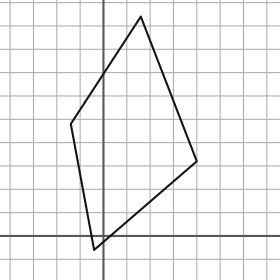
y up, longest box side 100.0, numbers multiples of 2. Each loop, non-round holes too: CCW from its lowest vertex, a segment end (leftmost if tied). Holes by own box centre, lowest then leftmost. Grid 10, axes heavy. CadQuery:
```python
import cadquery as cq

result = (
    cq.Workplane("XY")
    .moveTo(-4.0, -6.0)
    .lineTo(40.0, 32.0)
    .lineTo(16.0, 94.0)
    .lineTo(-14.0, 48.0)
    .close()
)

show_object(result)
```